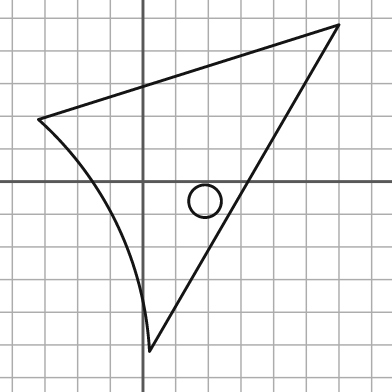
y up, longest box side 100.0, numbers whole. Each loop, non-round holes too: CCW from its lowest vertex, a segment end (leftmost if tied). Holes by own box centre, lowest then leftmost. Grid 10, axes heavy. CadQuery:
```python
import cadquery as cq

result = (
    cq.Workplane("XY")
    .moveTo(2.0, -52.0)
    .lineTo(60.0, 48.0)
    .lineTo(-32.0, 19.0)
    .threePointArc((-8.0, -13.0), (2.0, -52.0))
    .close()
    .moveTo(19.0, -6.0)
    .circle(5.0)
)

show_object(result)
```